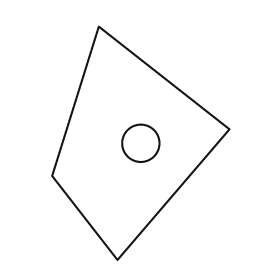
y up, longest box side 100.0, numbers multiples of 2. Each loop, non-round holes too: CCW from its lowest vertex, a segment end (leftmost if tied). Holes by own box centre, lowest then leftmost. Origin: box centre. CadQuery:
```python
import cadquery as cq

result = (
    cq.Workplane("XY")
    .moveTo(-10.0, -50.0)
    .lineTo(38.0, 6.0)
    .lineTo(-18.0, 50.0)
    .lineTo(-38.0, -14.0)
    .close()
    .moveTo(0.0, 0.0)
    .circle(8.0)
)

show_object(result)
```